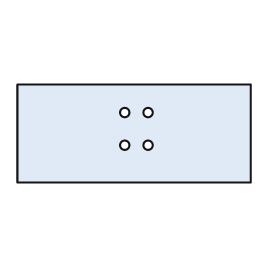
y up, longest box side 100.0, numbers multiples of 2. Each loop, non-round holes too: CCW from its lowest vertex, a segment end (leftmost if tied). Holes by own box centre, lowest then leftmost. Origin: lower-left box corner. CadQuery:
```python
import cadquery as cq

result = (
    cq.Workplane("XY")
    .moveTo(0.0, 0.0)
    .lineTo(100.0, 0.0)
    .lineTo(100.0, 42.0)
    .lineTo(0.0, 42.0)
    .close()
    .moveTo(46.0, 16.0)
    .circle(2.0)
    .moveTo(56.0, 16.0)
    .circle(2.0)
    .moveTo(46.0, 30.0)
    .circle(2.0)
    .moveTo(56.0, 30.0)
    .circle(2.0)
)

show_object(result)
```